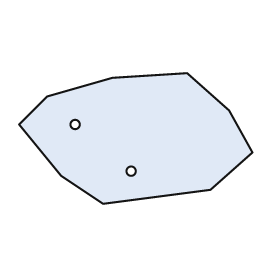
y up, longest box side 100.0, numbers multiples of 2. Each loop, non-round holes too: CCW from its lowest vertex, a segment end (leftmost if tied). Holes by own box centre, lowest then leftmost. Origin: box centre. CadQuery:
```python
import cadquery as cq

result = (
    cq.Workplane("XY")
    .moveTo(-14.0, -28.0)
    .lineTo(32.0, -22.0)
    .lineTo(50.0, -6.0)
    .lineTo(40.0, 12.0)
    .lineTo(22.0, 28.0)
    .lineTo(-10.0, 26.0)
    .lineTo(-38.0, 18.0)
    .lineTo(-50.0, 6.0)
    .lineTo(-32.0, -16.0)
    .close()
    .moveTo(-2.0, -14.0)
    .circle(2.0)
    .moveTo(-26.0, 6.0)
    .circle(2.0)
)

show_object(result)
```